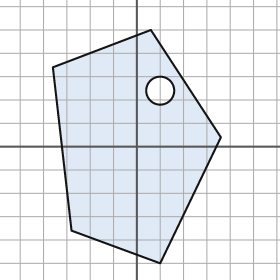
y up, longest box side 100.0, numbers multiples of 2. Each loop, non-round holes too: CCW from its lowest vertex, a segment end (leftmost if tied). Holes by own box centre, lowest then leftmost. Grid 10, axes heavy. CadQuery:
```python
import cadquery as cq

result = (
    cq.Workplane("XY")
    .moveTo(10.0, -50.0)
    .lineTo(36.0, 4.0)
    .lineTo(6.0, 50.0)
    .lineTo(-36.0, 34.0)
    .lineTo(-28.0, -36.0)
    .close()
    .moveTo(10.0, 24.0)
    .circle(6.0)
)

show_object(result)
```